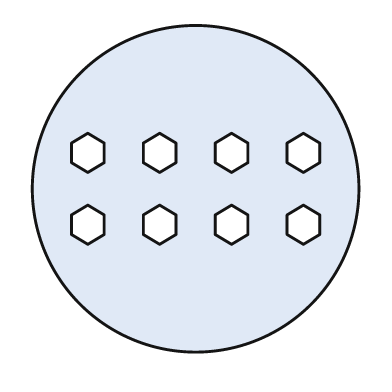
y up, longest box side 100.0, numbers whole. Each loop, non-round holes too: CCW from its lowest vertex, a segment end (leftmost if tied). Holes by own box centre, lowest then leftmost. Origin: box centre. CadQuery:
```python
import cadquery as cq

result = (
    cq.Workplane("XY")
    .moveTo(0.0, 0.0)
    .circle(50.0)
    .moveTo(-33.0, -17.0)
    .lineTo(-28.0, -14.0)
    .lineTo(-28.0, -8.0)
    .lineTo(-33.0, -5.0)
    .lineTo(-38.0, -8.0)
    .lineTo(-38.0, -14.0)
    .close()
    .moveTo(-11.0, -17.0)
    .lineTo(-6.0, -14.0)
    .lineTo(-6.0, -8.0)
    .lineTo(-11.0, -5.0)
    .lineTo(-16.0, -8.0)
    .lineTo(-16.0, -14.0)
    .close()
    .moveTo(11.0, -17.0)
    .lineTo(16.0, -14.0)
    .lineTo(16.0, -8.0)
    .lineTo(11.0, -5.0)
    .lineTo(6.0, -8.0)
    .lineTo(6.0, -14.0)
    .close()
    .moveTo(33.0, -17.0)
    .lineTo(38.0, -14.0)
    .lineTo(38.0, -8.0)
    .lineTo(33.0, -5.0)
    .lineTo(28.0, -8.0)
    .lineTo(28.0, -14.0)
    .close()
    .moveTo(-33.0, 5.0)
    .lineTo(-28.0, 8.0)
    .lineTo(-28.0, 14.0)
    .lineTo(-33.0, 17.0)
    .lineTo(-38.0, 14.0)
    .lineTo(-38.0, 8.0)
    .close()
    .moveTo(-11.0, 5.0)
    .lineTo(-6.0, 8.0)
    .lineTo(-6.0, 14.0)
    .lineTo(-11.0, 17.0)
    .lineTo(-16.0, 14.0)
    .lineTo(-16.0, 8.0)
    .close()
    .moveTo(11.0, 5.0)
    .lineTo(16.0, 8.0)
    .lineTo(16.0, 14.0)
    .lineTo(11.0, 17.0)
    .lineTo(6.0, 14.0)
    .lineTo(6.0, 8.0)
    .close()
    .moveTo(33.0, 5.0)
    .lineTo(38.0, 8.0)
    .lineTo(38.0, 14.0)
    .lineTo(33.0, 17.0)
    .lineTo(28.0, 14.0)
    .lineTo(28.0, 8.0)
    .close()
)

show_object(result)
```